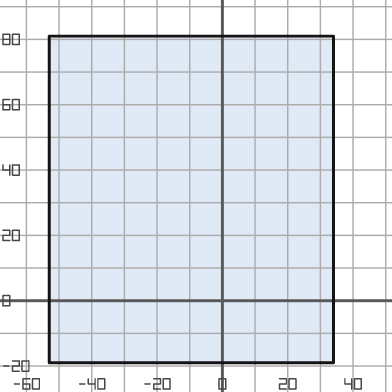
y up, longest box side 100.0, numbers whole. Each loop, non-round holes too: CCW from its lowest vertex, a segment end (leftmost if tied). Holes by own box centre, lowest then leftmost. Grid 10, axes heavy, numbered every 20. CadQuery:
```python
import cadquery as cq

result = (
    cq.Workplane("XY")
    .moveTo(-53.0, -19.0)
    .lineTo(34.0, -19.0)
    .lineTo(34.0, 81.0)
    .lineTo(-53.0, 81.0)
    .close()
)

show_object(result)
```